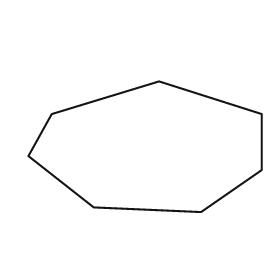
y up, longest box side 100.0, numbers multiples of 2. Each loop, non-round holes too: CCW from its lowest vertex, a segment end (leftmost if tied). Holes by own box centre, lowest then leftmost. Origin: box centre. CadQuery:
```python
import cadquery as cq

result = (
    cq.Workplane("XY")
    .moveTo(24.0, -28.0)
    .lineTo(50.0, -10.0)
    .lineTo(50.0, 14.0)
    .lineTo(6.0, 28.0)
    .lineTo(-40.0, 14.0)
    .lineTo(-50.0, -4.0)
    .lineTo(-22.0, -26.0)
    .close()
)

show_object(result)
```